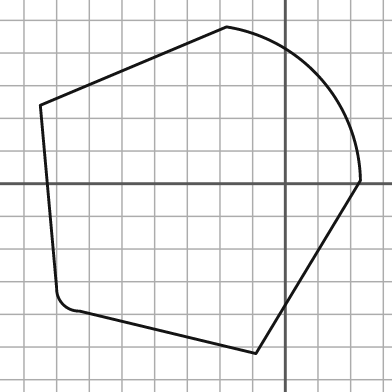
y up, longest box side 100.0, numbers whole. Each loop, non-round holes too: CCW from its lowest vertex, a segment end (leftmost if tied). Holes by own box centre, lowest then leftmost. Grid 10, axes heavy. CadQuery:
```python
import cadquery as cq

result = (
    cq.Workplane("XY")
    .moveTo(-9.0, -52.0)
    .lineTo(23.0, 1.0)
    .threePointArc((11.0, 32.0), (-18.0, 48.0))
    .lineTo(-75.0, 24.0)
    .lineTo(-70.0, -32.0)
    .threePointArc((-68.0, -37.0), (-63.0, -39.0))
    .close()
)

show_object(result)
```